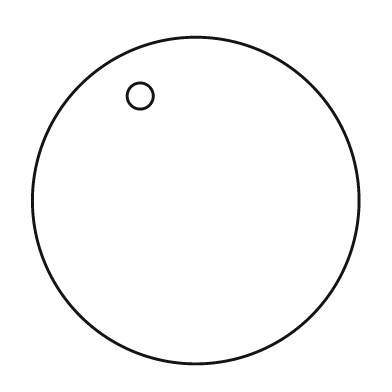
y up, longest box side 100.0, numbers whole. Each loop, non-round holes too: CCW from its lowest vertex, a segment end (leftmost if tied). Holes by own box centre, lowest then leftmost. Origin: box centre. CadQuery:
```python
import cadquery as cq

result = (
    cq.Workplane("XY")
    .moveTo(0.0, 0.0)
    .circle(50.0)
    .moveTo(-17.0, 32.0)
    .circle(4.0)
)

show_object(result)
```